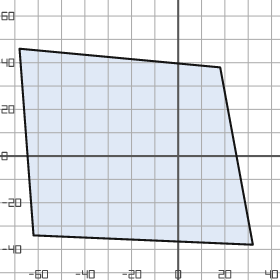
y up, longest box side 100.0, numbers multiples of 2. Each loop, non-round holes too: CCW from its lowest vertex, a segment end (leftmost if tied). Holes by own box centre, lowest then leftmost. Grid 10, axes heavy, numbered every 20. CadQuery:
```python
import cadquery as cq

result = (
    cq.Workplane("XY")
    .moveTo(32.0, -38.0)
    .lineTo(18.0, 38.0)
    .lineTo(-68.0, 46.0)
    .lineTo(-62.0, -34.0)
    .close()
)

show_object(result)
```